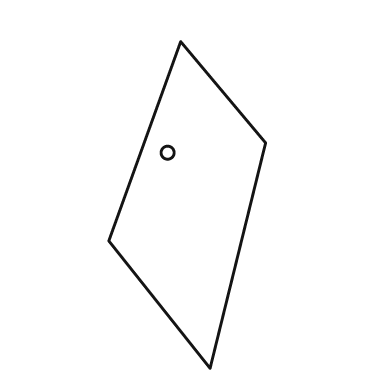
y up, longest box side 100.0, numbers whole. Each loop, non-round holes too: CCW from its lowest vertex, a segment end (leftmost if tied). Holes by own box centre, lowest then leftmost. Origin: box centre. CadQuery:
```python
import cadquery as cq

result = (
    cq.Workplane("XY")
    .moveTo(7.0, -50.0)
    .lineTo(24.0, 19.0)
    .lineTo(-2.0, 50.0)
    .lineTo(-24.0, -11.0)
    .close()
    .moveTo(-6.0, 16.0)
    .circle(2.0)
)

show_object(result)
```